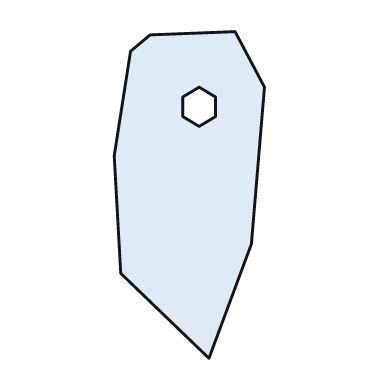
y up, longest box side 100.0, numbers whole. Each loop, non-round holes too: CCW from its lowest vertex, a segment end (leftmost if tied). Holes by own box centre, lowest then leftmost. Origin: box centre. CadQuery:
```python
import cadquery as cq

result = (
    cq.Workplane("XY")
    .moveTo(6.0, -50.0)
    .lineTo(19.0, -15.0)
    .lineTo(23.0, 33.0)
    .lineTo(14.0, 50.0)
    .lineTo(-12.0, 49.0)
    .lineTo(-18.0, 44.0)
    .lineTo(-23.0, 12.0)
    .lineTo(-21.0, -24.0)
    .close()
    .moveTo(3.0, 21.0)
    .lineTo(8.0, 24.0)
    .lineTo(8.0, 30.0)
    .lineTo(3.0, 33.0)
    .lineTo(-2.0, 30.0)
    .lineTo(-2.0, 24.0)
    .close()
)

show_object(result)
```